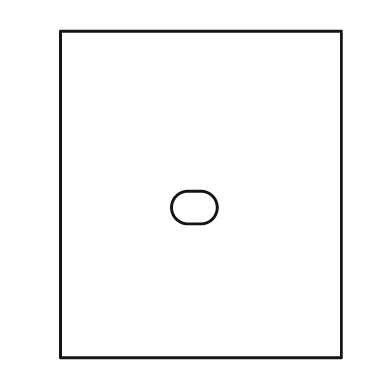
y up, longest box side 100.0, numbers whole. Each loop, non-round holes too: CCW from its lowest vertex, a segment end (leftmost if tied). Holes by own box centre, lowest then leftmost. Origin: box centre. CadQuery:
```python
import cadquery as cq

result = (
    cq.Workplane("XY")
    .moveTo(-43.0, -50.0)
    .lineTo(43.0, -50.0)
    .lineTo(43.0, 50.0)
    .lineTo(-43.0, 50.0)
    .close()
    .moveTo(-4.0, -9.0)
    .lineTo(0.0, -9.0)
    .threePointArc((5.0, -4.0), (0.0, 1.0))
    .lineTo(-4.0, 1.0)
    .threePointArc((-9.0, -4.0), (-4.0, -9.0))
    .close()
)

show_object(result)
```